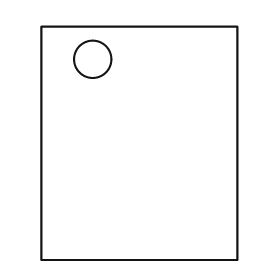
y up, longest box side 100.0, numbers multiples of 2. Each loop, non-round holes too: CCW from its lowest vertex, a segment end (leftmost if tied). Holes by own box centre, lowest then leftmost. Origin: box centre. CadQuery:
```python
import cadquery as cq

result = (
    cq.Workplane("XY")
    .moveTo(-42.0, -50.0)
    .lineTo(42.0, -50.0)
    .lineTo(42.0, 50.0)
    .lineTo(-42.0, 50.0)
    .close()
    .moveTo(-20.0, 36.0)
    .circle(8.0)
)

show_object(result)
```